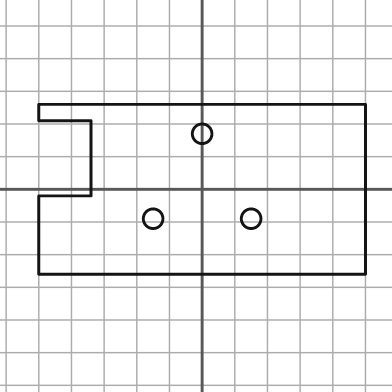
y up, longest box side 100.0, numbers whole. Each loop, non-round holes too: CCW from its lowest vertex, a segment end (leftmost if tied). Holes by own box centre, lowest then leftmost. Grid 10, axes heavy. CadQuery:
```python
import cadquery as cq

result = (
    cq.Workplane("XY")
    .moveTo(-50.0, -26.0)
    .lineTo(50.0, -26.0)
    .lineTo(50.0, 26.0)
    .lineTo(-50.0, 26.0)
    .lineTo(-50.0, 21.0)
    .lineTo(-34.0, 21.0)
    .lineTo(-34.0, -2.0)
    .lineTo(-50.0, -2.0)
    .close()
    .moveTo(-15.0, -9.0)
    .circle(3.0)
    .moveTo(15.0, -9.0)
    .circle(3.0)
    .moveTo(0.0, 17.0)
    .circle(3.0)
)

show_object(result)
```